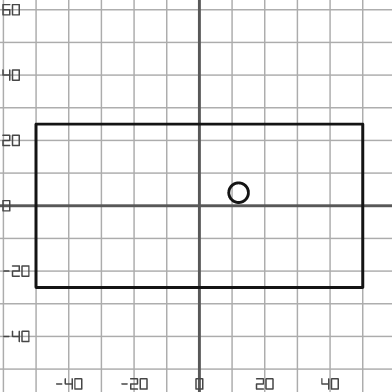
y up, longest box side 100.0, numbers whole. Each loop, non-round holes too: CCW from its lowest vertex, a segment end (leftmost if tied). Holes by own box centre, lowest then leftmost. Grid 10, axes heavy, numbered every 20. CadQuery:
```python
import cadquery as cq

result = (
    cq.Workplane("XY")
    .moveTo(-50.0, -25.0)
    .lineTo(50.0, -25.0)
    .lineTo(50.0, 25.0)
    .lineTo(-50.0, 25.0)
    .close()
    .moveTo(12.0, 4.0)
    .circle(3.0)
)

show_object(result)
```